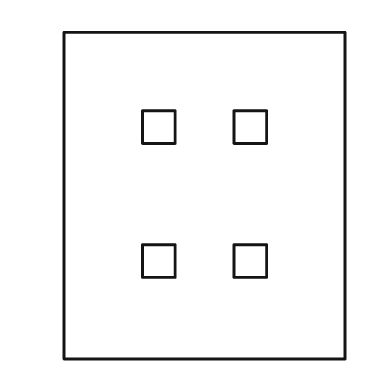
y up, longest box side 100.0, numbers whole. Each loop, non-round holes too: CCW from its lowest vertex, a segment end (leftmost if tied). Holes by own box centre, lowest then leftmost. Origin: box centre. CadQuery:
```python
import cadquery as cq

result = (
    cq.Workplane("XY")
    .moveTo(-43.0, -50.0)
    .lineTo(43.0, -50.0)
    .lineTo(43.0, 50.0)
    .lineTo(-43.0, 50.0)
    .close()
    .moveTo(-19.0, -25.0)
    .lineTo(-9.0, -25.0)
    .lineTo(-9.0, -15.0)
    .lineTo(-19.0, -15.0)
    .close()
    .moveTo(9.0, -25.0)
    .lineTo(19.0, -25.0)
    .lineTo(19.0, -15.0)
    .lineTo(9.0, -15.0)
    .close()
    .moveTo(-19.0, 16.0)
    .lineTo(-9.0, 16.0)
    .lineTo(-9.0, 26.0)
    .lineTo(-19.0, 26.0)
    .close()
    .moveTo(9.0, 16.0)
    .lineTo(19.0, 16.0)
    .lineTo(19.0, 26.0)
    .lineTo(9.0, 26.0)
    .close()
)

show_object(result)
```